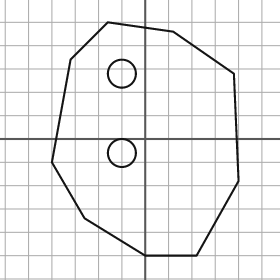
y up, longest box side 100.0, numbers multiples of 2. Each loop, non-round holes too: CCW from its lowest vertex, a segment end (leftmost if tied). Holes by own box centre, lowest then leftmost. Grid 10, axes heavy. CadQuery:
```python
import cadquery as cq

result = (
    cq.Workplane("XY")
    .moveTo(0.0, -50.0)
    .lineTo(22.0, -50.0)
    .lineTo(40.0, -18.0)
    .lineTo(38.0, 28.0)
    .lineTo(12.0, 46.0)
    .lineTo(-16.0, 50.0)
    .lineTo(-32.0, 34.0)
    .lineTo(-40.0, -10.0)
    .lineTo(-26.0, -34.0)
    .close()
    .moveTo(-10.0, -6.0)
    .circle(6.0)
    .moveTo(-10.0, 28.0)
    .circle(6.0)
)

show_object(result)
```